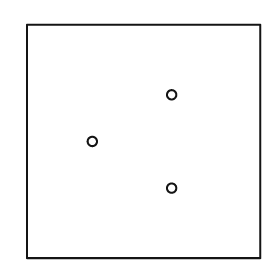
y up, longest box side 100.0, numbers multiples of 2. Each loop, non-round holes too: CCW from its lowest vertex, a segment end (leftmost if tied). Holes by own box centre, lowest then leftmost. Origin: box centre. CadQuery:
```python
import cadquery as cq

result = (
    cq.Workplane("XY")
    .moveTo(-50.0, -50.0)
    .lineTo(50.0, -50.0)
    .lineTo(50.0, 50.0)
    .lineTo(-50.0, 50.0)
    .close()
    .moveTo(12.0, -20.0)
    .circle(2.0)
    .moveTo(-22.0, 0.0)
    .circle(2.0)
    .moveTo(12.0, 20.0)
    .circle(2.0)
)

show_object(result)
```